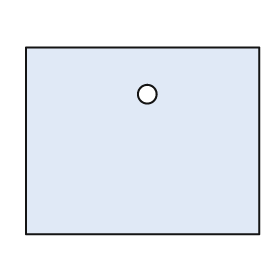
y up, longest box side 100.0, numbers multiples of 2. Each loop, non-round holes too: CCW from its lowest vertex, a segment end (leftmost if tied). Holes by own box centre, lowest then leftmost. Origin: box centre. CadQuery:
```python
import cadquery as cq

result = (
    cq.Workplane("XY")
    .moveTo(-50.0, -40.0)
    .lineTo(50.0, -40.0)
    .lineTo(50.0, 40.0)
    .lineTo(-50.0, 40.0)
    .close()
    .moveTo(2.0, 20.0)
    .circle(4.0)
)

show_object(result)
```